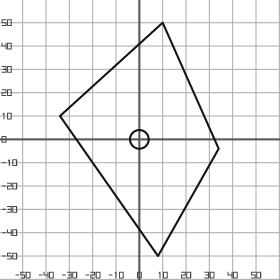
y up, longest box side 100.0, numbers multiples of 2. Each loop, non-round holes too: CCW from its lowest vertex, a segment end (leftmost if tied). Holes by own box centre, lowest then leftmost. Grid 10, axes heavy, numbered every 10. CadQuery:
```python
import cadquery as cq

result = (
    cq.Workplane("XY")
    .moveTo(8.0, -50.0)
    .lineTo(34.0, -4.0)
    .lineTo(10.0, 50.0)
    .lineTo(-34.0, 10.0)
    .close()
    .moveTo(0.0, 0.0)
    .circle(4.0)
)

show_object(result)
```